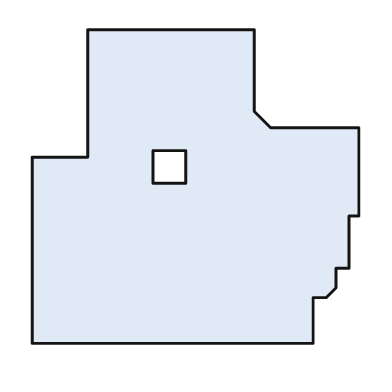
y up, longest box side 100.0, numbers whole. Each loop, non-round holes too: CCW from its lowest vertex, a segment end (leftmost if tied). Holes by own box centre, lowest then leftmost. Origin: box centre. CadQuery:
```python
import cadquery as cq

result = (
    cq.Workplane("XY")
    .moveTo(-50.0, -48.0)
    .lineTo(36.0, -48.0)
    .lineTo(36.0, -34.0)
    .lineTo(40.0, -34.0)
    .lineTo(43.0, -31.0)
    .lineTo(43.0, -25.0)
    .lineTo(47.0, -25.0)
    .lineTo(47.0, -9.0)
    .lineTo(50.0, -9.0)
    .lineTo(50.0, 18.0)
    .lineTo(23.0, 18.0)
    .lineTo(18.0, 23.0)
    .lineTo(18.0, 48.0)
    .lineTo(-33.0, 48.0)
    .lineTo(-33.0, 9.0)
    .lineTo(-50.0, 9.0)
    .close()
    .moveTo(-13.0, 1.0)
    .lineTo(-3.0, 1.0)
    .lineTo(-3.0, 11.0)
    .lineTo(-13.0, 11.0)
    .close()
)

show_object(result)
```